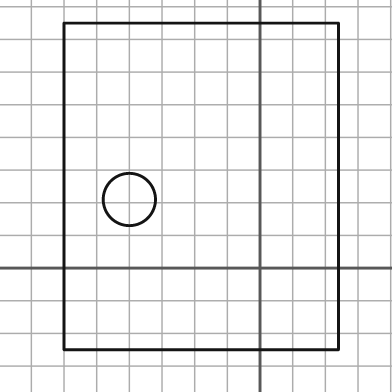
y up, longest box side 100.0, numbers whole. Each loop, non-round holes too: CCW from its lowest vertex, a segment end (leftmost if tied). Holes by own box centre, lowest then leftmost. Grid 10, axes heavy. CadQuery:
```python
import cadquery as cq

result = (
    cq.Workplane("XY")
    .moveTo(-60.0, -25.0)
    .lineTo(24.0, -25.0)
    .lineTo(24.0, 75.0)
    .lineTo(-60.0, 75.0)
    .close()
    .moveTo(-40.0, 21.0)
    .circle(8.0)
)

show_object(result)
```